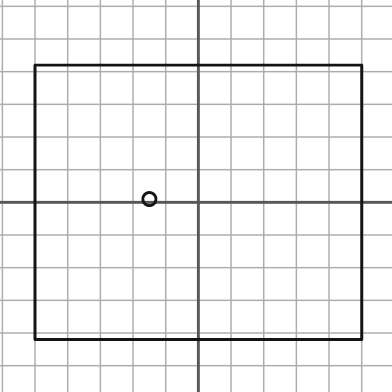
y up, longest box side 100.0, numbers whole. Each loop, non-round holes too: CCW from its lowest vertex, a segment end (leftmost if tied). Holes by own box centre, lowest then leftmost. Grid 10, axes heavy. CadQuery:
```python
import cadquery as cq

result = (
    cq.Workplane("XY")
    .moveTo(-50.0, -42.0)
    .lineTo(50.0, -42.0)
    .lineTo(50.0, 42.0)
    .lineTo(-50.0, 42.0)
    .close()
    .moveTo(-15.0, 1.0)
    .circle(2.0)
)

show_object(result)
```